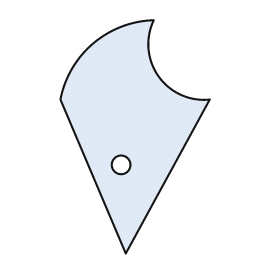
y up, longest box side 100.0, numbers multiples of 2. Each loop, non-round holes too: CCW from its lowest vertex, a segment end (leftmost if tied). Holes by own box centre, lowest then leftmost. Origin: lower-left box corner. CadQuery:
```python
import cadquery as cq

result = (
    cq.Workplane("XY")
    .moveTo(28.0, 0.0)
    .lineTo(64.0, 66.0)
    .threePointArc((42.0, 76.0), (40.0, 100.0))
    .threePointArc((14.0, 90.0), (0.0, 66.0))
    .close()
    .moveTo(26.0, 38.0)
    .circle(4.0)
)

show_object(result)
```